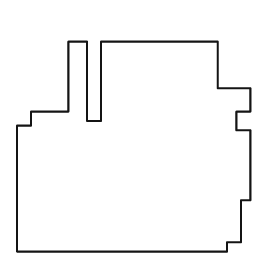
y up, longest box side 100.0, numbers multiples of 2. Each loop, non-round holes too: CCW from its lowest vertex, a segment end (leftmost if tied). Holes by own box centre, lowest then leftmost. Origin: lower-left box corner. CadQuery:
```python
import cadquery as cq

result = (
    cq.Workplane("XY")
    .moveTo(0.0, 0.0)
    .lineTo(90.0, 0.0)
    .lineTo(90.0, 4.0)
    .lineTo(96.0, 4.0)
    .lineTo(96.0, 22.0)
    .lineTo(100.0, 22.0)
    .lineTo(100.0, 52.0)
    .lineTo(94.0, 52.0)
    .lineTo(94.0, 60.0)
    .lineTo(100.0, 60.0)
    .lineTo(100.0, 70.0)
    .lineTo(86.0, 70.0)
    .lineTo(86.0, 90.0)
    .lineTo(36.0, 90.0)
    .lineTo(36.0, 56.0)
    .lineTo(30.0, 56.0)
    .lineTo(30.0, 90.0)
    .lineTo(22.0, 90.0)
    .lineTo(22.0, 60.0)
    .lineTo(6.0, 60.0)
    .lineTo(6.0, 54.0)
    .lineTo(0.0, 54.0)
    .close()
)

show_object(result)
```